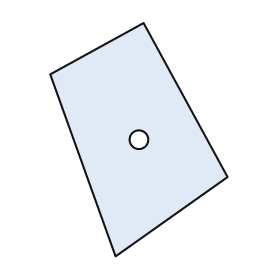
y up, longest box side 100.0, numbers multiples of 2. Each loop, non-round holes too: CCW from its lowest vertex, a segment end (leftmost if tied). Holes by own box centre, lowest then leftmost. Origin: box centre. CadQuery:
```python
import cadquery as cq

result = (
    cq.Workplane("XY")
    .moveTo(-10.0, -50.0)
    .lineTo(38.0, -16.0)
    .lineTo(2.0, 50.0)
    .lineTo(-38.0, 28.0)
    .close()
    .moveTo(0.0, 0.0)
    .circle(4.0)
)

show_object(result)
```